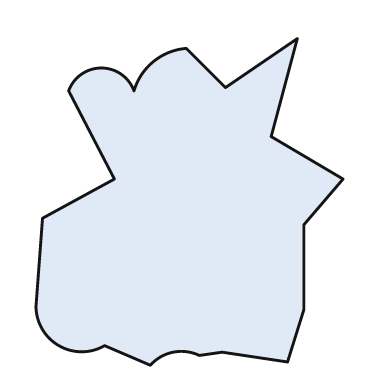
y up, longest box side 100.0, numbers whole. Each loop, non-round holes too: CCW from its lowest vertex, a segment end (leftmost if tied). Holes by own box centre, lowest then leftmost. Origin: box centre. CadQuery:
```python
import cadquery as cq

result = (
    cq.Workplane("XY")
    .moveTo(-12.0, -50.0)
    .threePointArc((-5.0, -46.0), (3.0, -47.0))
    .lineTo(10.0, -46.0)
    .lineTo(30.0, -49.0)
    .lineTo(35.0, -33.0)
    .lineTo(35.0, -7.0)
    .lineTo(47.0, 7.0)
    .lineTo(25.0, 20.0)
    .lineTo(33.0, 50.0)
    .lineTo(11.0, 35.0)
    .lineTo(-1.0, 47.0)
    .threePointArc((-11.0, 43.0), (-17.0, 34.0))
    .threePointArc((-27.0, 41.0), (-37.0, 34.0))
    .lineTo(-23.0, 7.0)
    .lineTo(-45.0, -5.0)
    .lineTo(-47.0, -32.0)
    .threePointArc((-40.0, -44.0), (-26.0, -44.0))
    .close()
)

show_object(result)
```